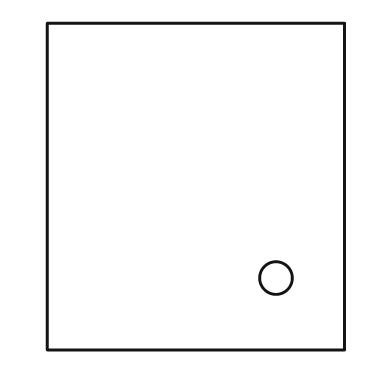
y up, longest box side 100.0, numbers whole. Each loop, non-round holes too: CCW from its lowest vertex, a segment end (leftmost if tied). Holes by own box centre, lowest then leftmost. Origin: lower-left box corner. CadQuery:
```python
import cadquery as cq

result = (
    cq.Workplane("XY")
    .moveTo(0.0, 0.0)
    .lineTo(91.0, 0.0)
    .lineTo(91.0, 100.0)
    .lineTo(0.0, 100.0)
    .close()
    .moveTo(70.0, 22.0)
    .circle(5.0)
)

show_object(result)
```